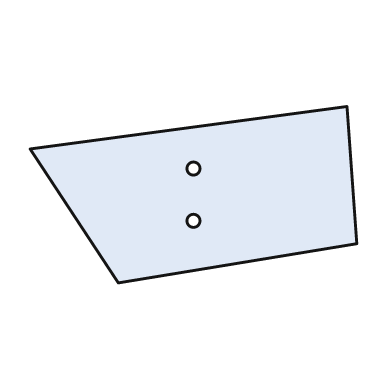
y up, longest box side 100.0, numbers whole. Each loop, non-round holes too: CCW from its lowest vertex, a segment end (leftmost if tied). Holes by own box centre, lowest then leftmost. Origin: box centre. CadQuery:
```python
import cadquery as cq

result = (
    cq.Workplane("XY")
    .moveTo(-23.0, -27.0)
    .lineTo(50.0, -15.0)
    .lineTo(47.0, 27.0)
    .lineTo(-50.0, 14.0)
    .close()
    .moveTo(0.0, -8.0)
    .circle(2.0)
    .moveTo(0.0, 8.0)
    .circle(2.0)
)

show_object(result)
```